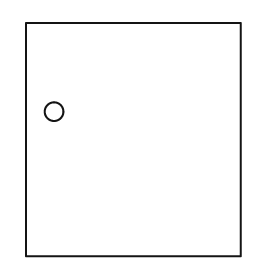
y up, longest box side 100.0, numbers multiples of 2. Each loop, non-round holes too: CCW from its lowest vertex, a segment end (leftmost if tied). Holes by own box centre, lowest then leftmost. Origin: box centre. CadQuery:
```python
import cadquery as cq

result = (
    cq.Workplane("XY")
    .moveTo(-46.0, -50.0)
    .lineTo(46.0, -50.0)
    .lineTo(46.0, 50.0)
    .lineTo(-46.0, 50.0)
    .close()
    .moveTo(-34.0, 12.0)
    .circle(4.0)
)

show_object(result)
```